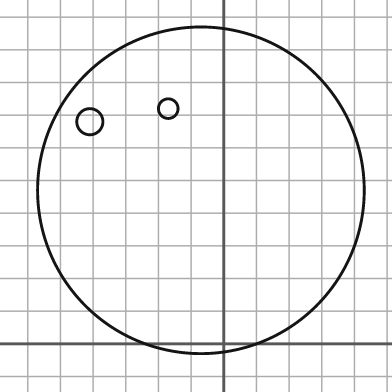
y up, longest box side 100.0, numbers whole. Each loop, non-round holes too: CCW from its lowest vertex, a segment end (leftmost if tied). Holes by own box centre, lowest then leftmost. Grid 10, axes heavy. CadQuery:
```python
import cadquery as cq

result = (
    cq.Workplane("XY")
    .moveTo(-7.0, 47.0)
    .circle(50.0)
    .moveTo(-41.0, 68.0)
    .circle(4.0)
    .moveTo(-17.0, 72.0)
    .circle(3.0)
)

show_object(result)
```